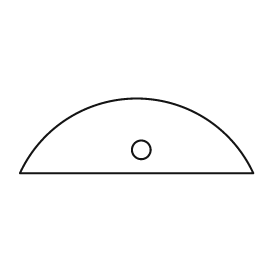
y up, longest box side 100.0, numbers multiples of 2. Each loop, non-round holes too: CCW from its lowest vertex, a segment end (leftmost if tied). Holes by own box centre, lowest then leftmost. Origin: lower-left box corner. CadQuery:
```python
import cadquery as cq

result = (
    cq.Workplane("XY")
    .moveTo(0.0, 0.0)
    .lineTo(100.0, 0.0)
    .threePointArc((50.0, 32.0), (0.0, 0.0))
    .close()
    .moveTo(52.0, 10.0)
    .circle(4.0)
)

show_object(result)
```